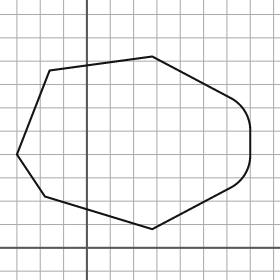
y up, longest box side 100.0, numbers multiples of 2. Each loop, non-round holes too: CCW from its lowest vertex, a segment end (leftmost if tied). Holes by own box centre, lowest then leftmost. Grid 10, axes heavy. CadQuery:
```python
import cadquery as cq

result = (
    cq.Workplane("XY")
    .moveTo(28.0, 8.0)
    .lineTo(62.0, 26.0)
    .threePointArc((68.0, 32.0), (70.0, 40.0))
    .lineTo(70.0, 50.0)
    .threePointArc((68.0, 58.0), (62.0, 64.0))
    .lineTo(28.0, 82.0)
    .lineTo(-16.0, 76.0)
    .lineTo(-30.0, 40.0)
    .lineTo(-18.0, 22.0)
    .close()
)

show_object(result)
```